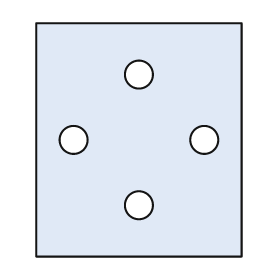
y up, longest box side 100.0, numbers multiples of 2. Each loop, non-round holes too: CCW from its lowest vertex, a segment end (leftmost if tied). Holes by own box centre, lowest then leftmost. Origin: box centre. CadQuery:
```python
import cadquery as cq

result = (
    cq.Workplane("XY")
    .moveTo(-44.0, -50.0)
    .lineTo(44.0, -50.0)
    .lineTo(44.0, 50.0)
    .lineTo(-44.0, 50.0)
    .close()
    .moveTo(0.0, -28.0)
    .circle(6.0)
    .moveTo(-28.0, 0.0)
    .circle(6.0)
    .moveTo(28.0, 0.0)
    .circle(6.0)
    .moveTo(0.0, 28.0)
    .circle(6.0)
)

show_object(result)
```